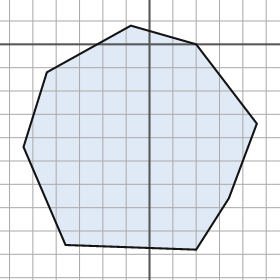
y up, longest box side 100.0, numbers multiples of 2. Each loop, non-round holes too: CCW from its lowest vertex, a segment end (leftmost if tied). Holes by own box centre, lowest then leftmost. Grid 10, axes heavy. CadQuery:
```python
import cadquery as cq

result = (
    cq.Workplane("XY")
    .moveTo(20.0, -88.0)
    .lineTo(34.0, -66.0)
    .lineTo(46.0, -34.0)
    .lineTo(20.0, 0.0)
    .lineTo(-8.0, 8.0)
    .lineTo(-44.0, -12.0)
    .lineTo(-54.0, -44.0)
    .lineTo(-36.0, -86.0)
    .close()
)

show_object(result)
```